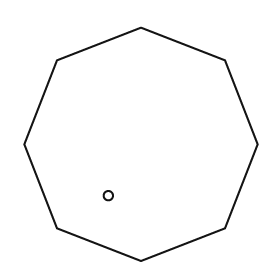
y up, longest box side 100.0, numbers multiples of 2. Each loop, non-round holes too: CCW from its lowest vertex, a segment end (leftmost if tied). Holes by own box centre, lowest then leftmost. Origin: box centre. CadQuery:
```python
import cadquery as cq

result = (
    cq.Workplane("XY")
    .moveTo(0.0, -50.0)
    .lineTo(36.0, -36.0)
    .lineTo(50.0, 0.0)
    .lineTo(36.0, 36.0)
    .lineTo(0.0, 50.0)
    .lineTo(-36.0, 36.0)
    .lineTo(-50.0, 0.0)
    .lineTo(-36.0, -36.0)
    .close()
    .moveTo(-14.0, -22.0)
    .circle(2.0)
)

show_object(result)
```